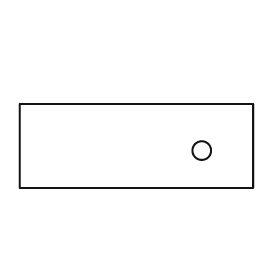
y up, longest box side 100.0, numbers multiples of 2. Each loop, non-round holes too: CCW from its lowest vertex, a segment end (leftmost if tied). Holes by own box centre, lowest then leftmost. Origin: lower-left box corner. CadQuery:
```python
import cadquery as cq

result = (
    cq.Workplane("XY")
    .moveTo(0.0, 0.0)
    .lineTo(100.0, 0.0)
    .lineTo(100.0, 36.0)
    .lineTo(0.0, 36.0)
    .close()
    .moveTo(78.0, 16.0)
    .circle(4.0)
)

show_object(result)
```